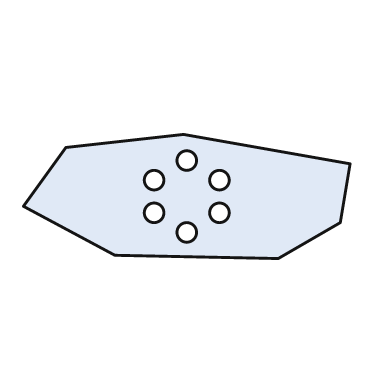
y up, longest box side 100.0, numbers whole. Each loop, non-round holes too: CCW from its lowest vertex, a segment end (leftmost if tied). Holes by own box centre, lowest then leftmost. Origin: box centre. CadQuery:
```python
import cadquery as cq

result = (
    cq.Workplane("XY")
    .moveTo(28.0, -19.0)
    .lineTo(47.0, -8.0)
    .lineTo(50.0, 10.0)
    .lineTo(-1.0, 19.0)
    .lineTo(-37.0, 15.0)
    .lineTo(-50.0, -3.0)
    .lineTo(-22.0, -18.0)
    .close()
    .moveTo(0.0, -11.0)
    .circle(3.0)
    .moveTo(-10.0, -5.0)
    .circle(3.0)
    .moveTo(10.0, -5.0)
    .circle(3.0)
    .moveTo(-10.0, 5.0)
    .circle(3.0)
    .moveTo(10.0, 5.0)
    .circle(3.0)
    .moveTo(0.0, 11.0)
    .circle(3.0)
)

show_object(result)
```